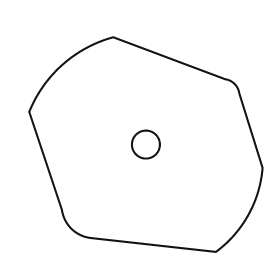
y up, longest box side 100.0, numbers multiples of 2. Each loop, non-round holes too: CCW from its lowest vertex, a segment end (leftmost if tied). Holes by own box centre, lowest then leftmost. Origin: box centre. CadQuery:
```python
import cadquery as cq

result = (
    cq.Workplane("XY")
    .moveTo(30.0, -46.0)
    .threePointArc((44.0, -30.0), (50.0, -10.0))
    .lineTo(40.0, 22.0)
    .threePointArc((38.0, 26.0), (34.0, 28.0))
    .lineTo(-14.0, 46.0)
    .threePointArc((-36.0, 34.0), (-50.0, 14.0))
    .lineTo(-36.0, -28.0)
    .threePointArc((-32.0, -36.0), (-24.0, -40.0))
    .close()
    .moveTo(0.0, 0.0)
    .circle(6.0)
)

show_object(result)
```